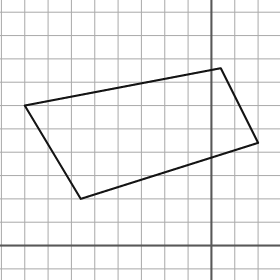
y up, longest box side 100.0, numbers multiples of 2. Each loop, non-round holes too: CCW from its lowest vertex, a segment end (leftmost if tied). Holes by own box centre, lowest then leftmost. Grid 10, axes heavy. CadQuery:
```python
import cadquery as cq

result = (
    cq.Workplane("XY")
    .moveTo(-56.0, 20.0)
    .lineTo(20.0, 44.0)
    .lineTo(4.0, 76.0)
    .lineTo(-80.0, 60.0)
    .close()
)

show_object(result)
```